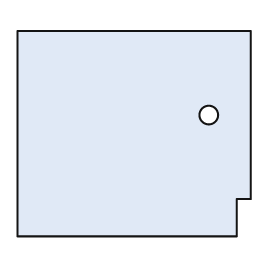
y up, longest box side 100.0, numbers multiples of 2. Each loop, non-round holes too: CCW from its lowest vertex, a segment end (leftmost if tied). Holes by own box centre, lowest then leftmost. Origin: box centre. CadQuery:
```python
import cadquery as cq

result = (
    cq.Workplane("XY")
    .moveTo(-50.0, -44.0)
    .lineTo(44.0, -44.0)
    .lineTo(44.0, -28.0)
    .lineTo(50.0, -28.0)
    .lineTo(50.0, 44.0)
    .lineTo(-50.0, 44.0)
    .close()
    .moveTo(32.0, 8.0)
    .circle(4.0)
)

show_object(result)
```